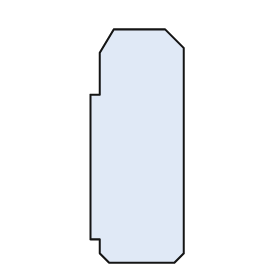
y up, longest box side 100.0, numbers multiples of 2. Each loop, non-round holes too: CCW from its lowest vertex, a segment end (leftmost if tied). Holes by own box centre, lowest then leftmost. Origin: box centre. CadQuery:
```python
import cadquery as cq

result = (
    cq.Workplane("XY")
    .moveTo(-12.0, -50.0)
    .lineTo(16.0, -50.0)
    .lineTo(20.0, -46.0)
    .lineTo(20.0, 42.0)
    .lineTo(12.0, 50.0)
    .lineTo(-10.0, 50.0)
    .lineTo(-16.0, 40.0)
    .lineTo(-16.0, 22.0)
    .lineTo(-20.0, 22.0)
    .lineTo(-20.0, -40.0)
    .lineTo(-16.0, -40.0)
    .lineTo(-16.0, -46.0)
    .close()
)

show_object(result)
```